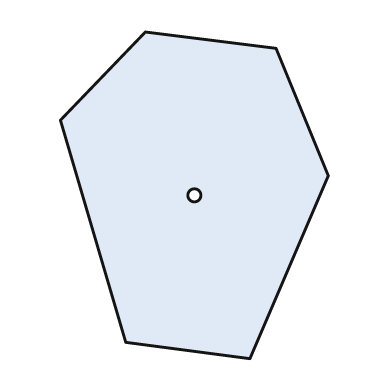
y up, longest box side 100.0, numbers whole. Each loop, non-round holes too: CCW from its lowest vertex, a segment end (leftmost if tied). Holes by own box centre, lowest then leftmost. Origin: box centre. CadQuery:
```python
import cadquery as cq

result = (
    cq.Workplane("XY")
    .moveTo(17.0, -50.0)
    .lineTo(41.0, 6.0)
    .lineTo(25.0, 45.0)
    .lineTo(-15.0, 50.0)
    .lineTo(-41.0, 23.0)
    .lineTo(-21.0, -45.0)
    .close()
    .moveTo(0.0, 0.0)
    .circle(2.0)
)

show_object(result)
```